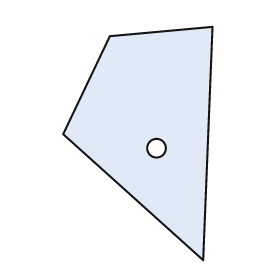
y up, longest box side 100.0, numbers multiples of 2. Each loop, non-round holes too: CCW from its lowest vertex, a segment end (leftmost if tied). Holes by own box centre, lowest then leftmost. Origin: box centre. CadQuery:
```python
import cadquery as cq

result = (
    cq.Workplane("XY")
    .moveTo(28.0, -50.0)
    .lineTo(32.0, 50.0)
    .lineTo(-12.0, 46.0)
    .lineTo(-32.0, 4.0)
    .close()
    .moveTo(8.0, -2.0)
    .circle(4.0)
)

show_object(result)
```